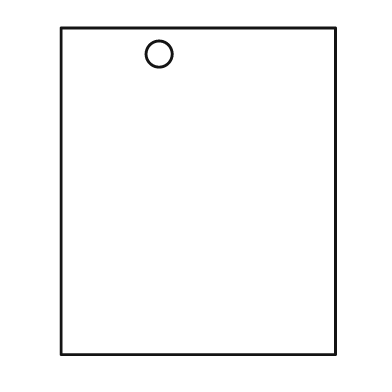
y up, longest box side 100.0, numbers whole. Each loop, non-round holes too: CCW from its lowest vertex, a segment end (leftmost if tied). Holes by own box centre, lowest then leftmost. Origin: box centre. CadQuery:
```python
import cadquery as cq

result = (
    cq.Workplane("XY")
    .moveTo(-42.0, -50.0)
    .lineTo(42.0, -50.0)
    .lineTo(42.0, 50.0)
    .lineTo(-42.0, 50.0)
    .close()
    .moveTo(-12.0, 42.0)
    .circle(4.0)
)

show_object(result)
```